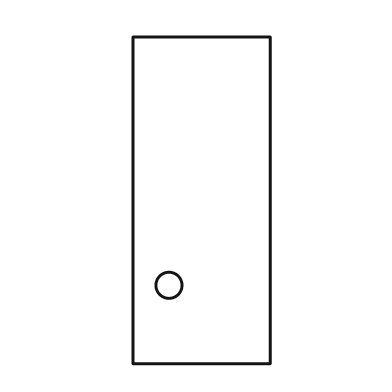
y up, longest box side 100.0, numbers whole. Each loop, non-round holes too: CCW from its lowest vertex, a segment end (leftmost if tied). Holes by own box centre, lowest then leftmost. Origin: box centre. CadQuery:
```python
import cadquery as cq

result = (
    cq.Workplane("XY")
    .moveTo(-21.0, -50.0)
    .lineTo(21.0, -50.0)
    .lineTo(21.0, 50.0)
    .lineTo(-21.0, 50.0)
    .close()
    .moveTo(-10.0, -26.0)
    .circle(4.0)
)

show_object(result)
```